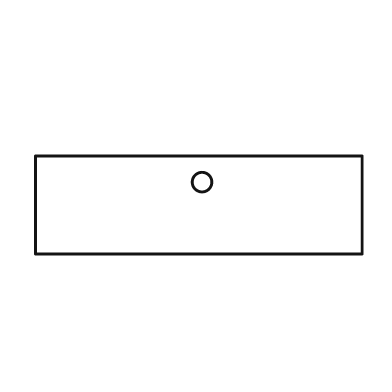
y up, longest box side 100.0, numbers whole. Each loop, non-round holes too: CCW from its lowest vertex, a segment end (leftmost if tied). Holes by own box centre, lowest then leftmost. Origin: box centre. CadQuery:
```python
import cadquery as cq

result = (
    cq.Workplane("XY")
    .moveTo(-50.0, -15.0)
    .lineTo(50.0, -15.0)
    .lineTo(50.0, 15.0)
    .lineTo(-50.0, 15.0)
    .close()
    .moveTo(1.0, 7.0)
    .circle(3.0)
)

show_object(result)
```